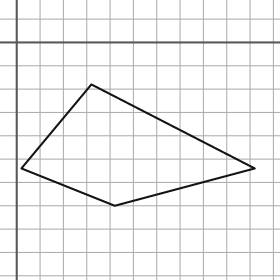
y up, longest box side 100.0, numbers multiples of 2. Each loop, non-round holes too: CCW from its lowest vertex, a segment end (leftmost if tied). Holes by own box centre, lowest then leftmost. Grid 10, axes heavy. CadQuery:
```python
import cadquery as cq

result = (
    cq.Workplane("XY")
    .moveTo(42.0, -70.0)
    .lineTo(102.0, -54.0)
    .lineTo(32.0, -18.0)
    .lineTo(2.0, -54.0)
    .close()
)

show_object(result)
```